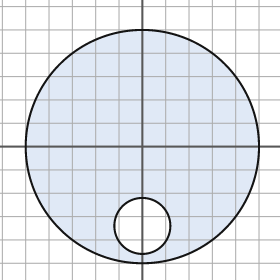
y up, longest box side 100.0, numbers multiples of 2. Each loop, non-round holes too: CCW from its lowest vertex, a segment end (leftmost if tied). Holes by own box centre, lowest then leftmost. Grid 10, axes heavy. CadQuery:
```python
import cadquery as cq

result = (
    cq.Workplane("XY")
    .moveTo(0.0, 0.0)
    .circle(50.0)
    .moveTo(0.0, -34.0)
    .circle(12.0)
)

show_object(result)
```